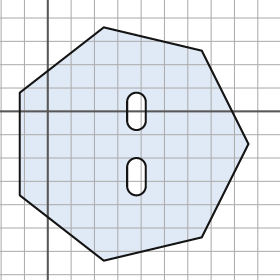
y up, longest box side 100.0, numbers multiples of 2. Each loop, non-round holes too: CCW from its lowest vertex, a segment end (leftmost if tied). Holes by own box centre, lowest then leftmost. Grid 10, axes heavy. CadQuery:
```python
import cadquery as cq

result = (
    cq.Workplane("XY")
    .moveTo(24.0, -64.0)
    .lineTo(66.0, -54.0)
    .lineTo(86.0, -14.0)
    .lineTo(66.0, 26.0)
    .lineTo(24.0, 36.0)
    .lineTo(-12.0, 8.0)
    .lineTo(-12.0, -36.0)
    .close()
    .moveTo(34.0, -32.0)
    .threePointArc((38.0, -36.0), (42.0, -32.0))
    .lineTo(42.0, -24.0)
    .threePointArc((38.0, -20.0), (34.0, -24.0))
    .close()
    .moveTo(34.0, -4.0)
    .threePointArc((38.0, -8.0), (42.0, -4.0))
    .lineTo(42.0, 4.0)
    .threePointArc((38.0, 8.0), (34.0, 4.0))
    .close()
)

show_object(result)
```